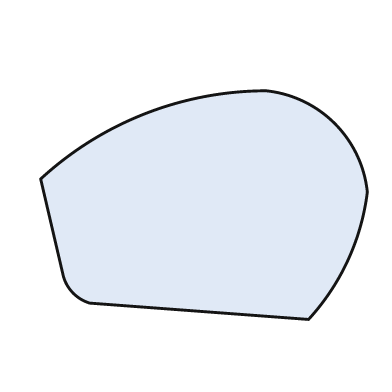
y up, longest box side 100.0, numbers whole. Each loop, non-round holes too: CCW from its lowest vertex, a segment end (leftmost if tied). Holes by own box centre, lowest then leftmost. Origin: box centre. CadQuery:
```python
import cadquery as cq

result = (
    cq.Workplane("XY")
    .moveTo(32.0, -35.0)
    .threePointArc((44.0, -17.0), (50.0, 4.0))
    .threePointArc((40.0, 25.0), (19.0, 35.0))
    .threePointArc((-18.0, 28.0), (-50.0, 8.0))
    .lineTo(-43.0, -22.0)
    .threePointArc((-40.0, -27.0), (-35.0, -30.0))
    .close()
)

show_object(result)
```